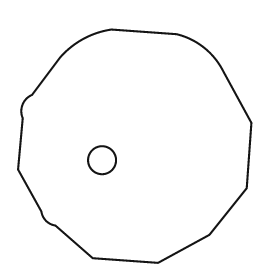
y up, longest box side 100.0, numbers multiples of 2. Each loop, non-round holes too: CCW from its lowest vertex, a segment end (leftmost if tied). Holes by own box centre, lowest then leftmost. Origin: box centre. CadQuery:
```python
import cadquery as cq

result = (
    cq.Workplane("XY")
    .moveTo(10.0, -50.0)
    .lineTo(32.0, -38.0)
    .lineTo(48.0, -18.0)
    .lineTo(50.0, 10.0)
    .lineTo(38.0, 32.0)
    .threePointArc((30.0, 42.0), (18.0, 48.0))
    .lineTo(-10.0, 50.0)
    .threePointArc((-22.0, 46.0), (-32.0, 38.0))
    .lineTo(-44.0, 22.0)
    .threePointArc((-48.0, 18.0), (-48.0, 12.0))
    .lineTo(-50.0, -10.0)
    .lineTo(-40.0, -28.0)
    .threePointArc((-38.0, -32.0), (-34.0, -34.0))
    .lineTo(-18.0, -48.0)
    .close()
    .moveTo(-14.0, -6.0)
    .circle(6.0)
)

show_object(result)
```